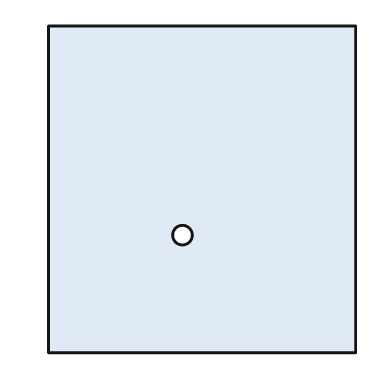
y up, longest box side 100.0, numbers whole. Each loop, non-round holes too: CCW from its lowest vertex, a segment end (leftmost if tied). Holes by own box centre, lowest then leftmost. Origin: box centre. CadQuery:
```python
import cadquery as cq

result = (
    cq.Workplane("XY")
    .moveTo(-47.0, -50.0)
    .lineTo(47.0, -50.0)
    .lineTo(47.0, 50.0)
    .lineTo(-47.0, 50.0)
    .close()
    .moveTo(-6.0, -14.0)
    .circle(3.0)
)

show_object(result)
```